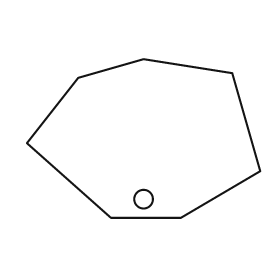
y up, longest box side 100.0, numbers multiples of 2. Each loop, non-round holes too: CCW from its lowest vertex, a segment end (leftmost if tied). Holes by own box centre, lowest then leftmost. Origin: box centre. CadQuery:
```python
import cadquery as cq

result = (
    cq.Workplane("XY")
    .moveTo(-14.0, -34.0)
    .lineTo(16.0, -34.0)
    .lineTo(50.0, -14.0)
    .lineTo(38.0, 28.0)
    .lineTo(0.0, 34.0)
    .lineTo(-28.0, 26.0)
    .lineTo(-50.0, -2.0)
    .close()
    .moveTo(0.0, -26.0)
    .circle(4.0)
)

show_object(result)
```